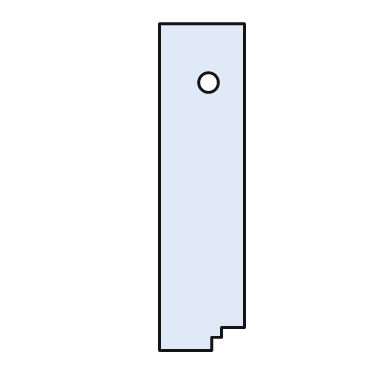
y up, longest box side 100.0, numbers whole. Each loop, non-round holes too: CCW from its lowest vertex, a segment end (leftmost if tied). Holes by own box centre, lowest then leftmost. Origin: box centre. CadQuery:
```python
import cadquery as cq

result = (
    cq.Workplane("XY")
    .moveTo(-13.0, -50.0)
    .lineTo(3.0, -50.0)
    .lineTo(3.0, -46.0)
    .lineTo(6.0, -46.0)
    .lineTo(6.0, -43.0)
    .lineTo(13.0, -43.0)
    .lineTo(13.0, 50.0)
    .lineTo(-13.0, 50.0)
    .close()
    .moveTo(2.0, 32.0)
    .circle(3.0)
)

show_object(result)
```